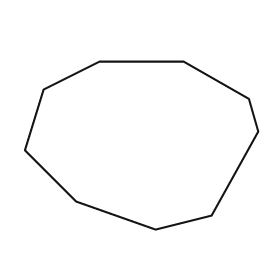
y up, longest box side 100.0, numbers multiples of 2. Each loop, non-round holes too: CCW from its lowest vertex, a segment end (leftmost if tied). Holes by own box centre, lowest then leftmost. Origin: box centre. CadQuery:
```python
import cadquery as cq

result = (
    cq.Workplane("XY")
    .moveTo(6.0, -36.0)
    .lineTo(30.0, -30.0)
    .lineTo(50.0, 6.0)
    .lineTo(46.0, 20.0)
    .lineTo(18.0, 36.0)
    .lineTo(-18.0, 36.0)
    .lineTo(-42.0, 24.0)
    .lineTo(-50.0, -2.0)
    .lineTo(-28.0, -24.0)
    .close()
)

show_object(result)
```